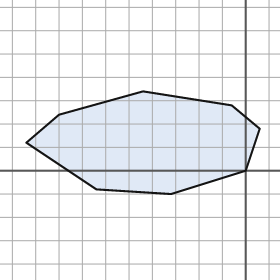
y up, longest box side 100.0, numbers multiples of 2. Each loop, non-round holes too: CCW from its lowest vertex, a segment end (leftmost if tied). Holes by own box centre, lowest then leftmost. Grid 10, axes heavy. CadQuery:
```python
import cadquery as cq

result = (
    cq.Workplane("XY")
    .moveTo(-32.0, -10.0)
    .lineTo(0.0, 0.0)
    .lineTo(6.0, 18.0)
    .lineTo(-6.0, 28.0)
    .lineTo(-44.0, 34.0)
    .lineTo(-80.0, 24.0)
    .lineTo(-94.0, 12.0)
    .lineTo(-64.0, -8.0)
    .close()
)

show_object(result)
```